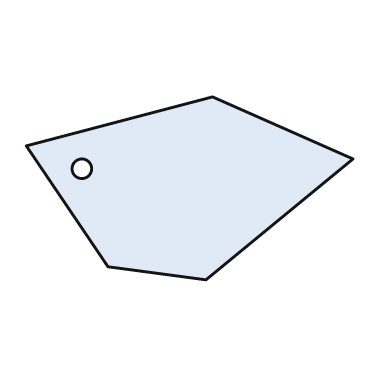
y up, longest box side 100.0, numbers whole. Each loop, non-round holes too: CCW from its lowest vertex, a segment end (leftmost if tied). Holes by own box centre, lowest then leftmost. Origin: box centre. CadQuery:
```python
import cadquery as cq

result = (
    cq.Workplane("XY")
    .moveTo(5.0, -28.0)
    .lineTo(50.0, 9.0)
    .lineTo(7.0, 28.0)
    .lineTo(-50.0, 13.0)
    .lineTo(-25.0, -24.0)
    .close()
    .moveTo(-33.0, 6.0)
    .circle(3.0)
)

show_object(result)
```